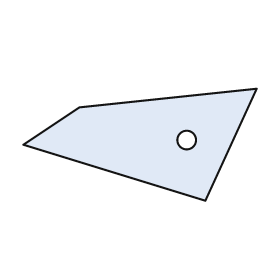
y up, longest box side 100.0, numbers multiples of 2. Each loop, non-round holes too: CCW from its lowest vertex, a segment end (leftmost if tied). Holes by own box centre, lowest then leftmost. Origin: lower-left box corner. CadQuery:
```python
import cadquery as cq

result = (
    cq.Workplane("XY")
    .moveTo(78.0, 0.0)
    .lineTo(100.0, 48.0)
    .lineTo(24.0, 40.0)
    .lineTo(0.0, 24.0)
    .close()
    .moveTo(70.0, 26.0)
    .circle(4.0)
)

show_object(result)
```